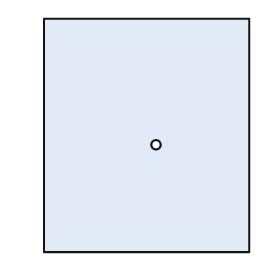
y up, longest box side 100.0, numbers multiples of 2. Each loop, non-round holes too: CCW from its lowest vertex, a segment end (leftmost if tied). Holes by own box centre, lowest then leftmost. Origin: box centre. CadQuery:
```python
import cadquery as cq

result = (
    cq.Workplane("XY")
    .moveTo(-44.0, -50.0)
    .lineTo(44.0, -50.0)
    .lineTo(44.0, 50.0)
    .lineTo(-44.0, 50.0)
    .close()
    .moveTo(4.0, -4.0)
    .circle(2.0)
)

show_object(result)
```